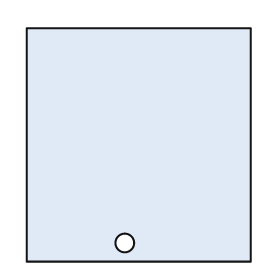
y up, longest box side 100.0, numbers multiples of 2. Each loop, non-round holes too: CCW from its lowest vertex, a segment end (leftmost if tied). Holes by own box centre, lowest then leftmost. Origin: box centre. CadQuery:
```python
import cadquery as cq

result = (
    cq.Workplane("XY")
    .moveTo(-48.0, -50.0)
    .lineTo(48.0, -50.0)
    .lineTo(48.0, 50.0)
    .lineTo(-48.0, 50.0)
    .close()
    .moveTo(-6.0, -42.0)
    .circle(4.0)
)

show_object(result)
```